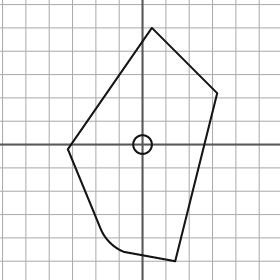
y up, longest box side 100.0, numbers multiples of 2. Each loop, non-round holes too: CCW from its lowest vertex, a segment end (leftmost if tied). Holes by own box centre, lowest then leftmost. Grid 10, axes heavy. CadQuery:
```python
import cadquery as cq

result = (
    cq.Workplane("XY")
    .moveTo(14.0, -50.0)
    .lineTo(32.0, 22.0)
    .lineTo(4.0, 50.0)
    .lineTo(-32.0, -2.0)
    .lineTo(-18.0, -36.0)
    .threePointArc((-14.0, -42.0), (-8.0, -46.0))
    .close()
    .moveTo(0.0, 0.0)
    .circle(4.0)
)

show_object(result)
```